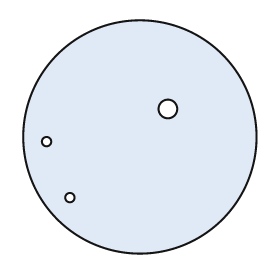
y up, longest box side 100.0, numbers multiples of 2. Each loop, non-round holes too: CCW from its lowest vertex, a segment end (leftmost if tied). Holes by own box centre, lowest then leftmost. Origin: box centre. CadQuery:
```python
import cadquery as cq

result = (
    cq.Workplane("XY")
    .moveTo(0.0, 0.0)
    .circle(50.0)
    .moveTo(-30.0, -26.0)
    .circle(2.0)
    .moveTo(-40.0, -2.0)
    .circle(2.0)
    .moveTo(12.0, 12.0)
    .circle(4.0)
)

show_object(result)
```